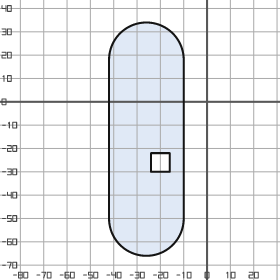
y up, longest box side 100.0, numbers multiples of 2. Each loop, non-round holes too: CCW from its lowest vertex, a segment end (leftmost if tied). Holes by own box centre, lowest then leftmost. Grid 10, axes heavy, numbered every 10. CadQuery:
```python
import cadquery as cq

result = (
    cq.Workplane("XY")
    .moveTo(-42.0, -50.0)
    .threePointArc((-26.0, -66.0), (-10.0, -50.0))
    .lineTo(-10.0, 18.0)
    .threePointArc((-26.0, 34.0), (-42.0, 18.0))
    .close()
    .moveTo(-24.0, -30.0)
    .lineTo(-16.0, -30.0)
    .lineTo(-16.0, -22.0)
    .lineTo(-24.0, -22.0)
    .close()
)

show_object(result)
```